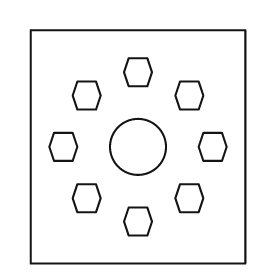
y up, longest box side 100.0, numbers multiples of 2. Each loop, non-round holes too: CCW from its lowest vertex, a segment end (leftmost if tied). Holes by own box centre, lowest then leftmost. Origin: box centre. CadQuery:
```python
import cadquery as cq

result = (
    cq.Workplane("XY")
    .moveTo(-46.0, -50.0)
    .lineTo(46.0, -50.0)
    .lineTo(46.0, 50.0)
    .lineTo(-46.0, 50.0)
    .close()
    .moveTo(-4.0, -38.0)
    .lineTo(4.0, -38.0)
    .lineTo(6.0, -32.0)
    .lineTo(4.0, -26.0)
    .lineTo(-4.0, -26.0)
    .lineTo(-6.0, -32.0)
    .close()
    .moveTo(-26.0, -28.0)
    .lineTo(-18.0, -28.0)
    .lineTo(-16.0, -22.0)
    .lineTo(-18.0, -16.0)
    .lineTo(-26.0, -16.0)
    .lineTo(-28.0, -22.0)
    .close()
    .moveTo(18.0, -28.0)
    .lineTo(26.0, -28.0)
    .lineTo(28.0, -22.0)
    .lineTo(26.0, -16.0)
    .lineTo(18.0, -16.0)
    .lineTo(16.0, -22.0)
    .close()
    .moveTo(-36.0, -6.0)
    .lineTo(-28.0, -6.0)
    .lineTo(-26.0, 0.0)
    .lineTo(-28.0, 6.0)
    .lineTo(-36.0, 6.0)
    .lineTo(-38.0, 0.0)
    .close()
    .moveTo(0.0, 0.0)
    .circle(12.0)
    .moveTo(28.0, -6.0)
    .lineTo(36.0, -6.0)
    .lineTo(38.0, 0.0)
    .lineTo(36.0, 6.0)
    .lineTo(28.0, 6.0)
    .lineTo(26.0, 0.0)
    .close()
    .moveTo(-26.0, 16.0)
    .lineTo(-18.0, 16.0)
    .lineTo(-16.0, 22.0)
    .lineTo(-18.0, 28.0)
    .lineTo(-26.0, 28.0)
    .lineTo(-28.0, 22.0)
    .close()
    .moveTo(18.0, 16.0)
    .lineTo(26.0, 16.0)
    .lineTo(28.0, 22.0)
    .lineTo(26.0, 28.0)
    .lineTo(18.0, 28.0)
    .lineTo(16.0, 22.0)
    .close()
    .moveTo(-4.0, 26.0)
    .lineTo(4.0, 26.0)
    .lineTo(6.0, 32.0)
    .lineTo(4.0, 38.0)
    .lineTo(-4.0, 38.0)
    .lineTo(-6.0, 32.0)
    .close()
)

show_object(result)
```